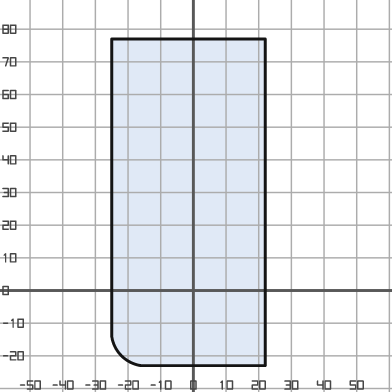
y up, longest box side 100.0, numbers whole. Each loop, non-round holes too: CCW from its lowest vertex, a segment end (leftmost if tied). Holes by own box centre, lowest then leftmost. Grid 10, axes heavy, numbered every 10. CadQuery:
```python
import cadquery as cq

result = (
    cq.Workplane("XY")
    .moveTo(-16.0, -23.0)
    .lineTo(22.0, -23.0)
    .lineTo(22.0, 77.0)
    .lineTo(-25.0, 77.0)
    .lineTo(-25.0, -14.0)
    .threePointArc((-22.0, -20.0), (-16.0, -23.0))
    .close()
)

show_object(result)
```